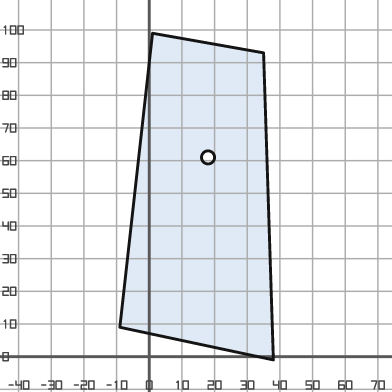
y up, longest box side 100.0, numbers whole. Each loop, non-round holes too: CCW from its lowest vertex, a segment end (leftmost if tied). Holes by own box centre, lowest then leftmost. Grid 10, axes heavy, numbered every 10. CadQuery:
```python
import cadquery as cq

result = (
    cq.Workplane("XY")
    .moveTo(38.0, -1.0)
    .lineTo(35.0, 93.0)
    .lineTo(1.0, 99.0)
    .lineTo(-9.0, 9.0)
    .close()
    .moveTo(18.0, 61.0)
    .circle(2.0)
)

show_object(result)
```